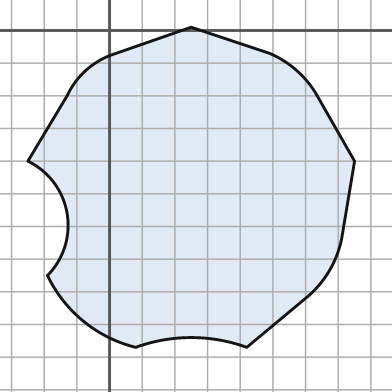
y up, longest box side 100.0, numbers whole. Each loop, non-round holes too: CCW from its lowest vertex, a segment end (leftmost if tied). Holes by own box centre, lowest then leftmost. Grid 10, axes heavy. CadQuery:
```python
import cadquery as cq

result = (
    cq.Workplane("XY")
    .moveTo(8.0, -97.0)
    .threePointArc((25.0, -94.0), (42.0, -97.0))
    .lineTo(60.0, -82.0)
    .threePointArc((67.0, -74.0), (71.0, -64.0))
    .lineTo(75.0, -40.0)
    .lineTo(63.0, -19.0)
    .threePointArc((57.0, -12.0), (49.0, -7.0))
    .lineTo(25.0, 1.0)
    .lineTo(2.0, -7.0)
    .threePointArc((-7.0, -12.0), (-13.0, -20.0))
    .lineTo(-25.0, -40.0)
    .threePointArc((-13.0, -56.0), (-19.0, -75.0))
    .threePointArc((-8.0, -89.0), (8.0, -97.0))
    .close()
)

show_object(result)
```